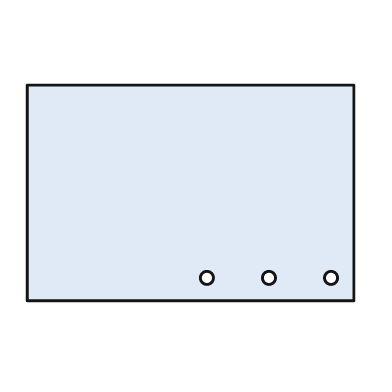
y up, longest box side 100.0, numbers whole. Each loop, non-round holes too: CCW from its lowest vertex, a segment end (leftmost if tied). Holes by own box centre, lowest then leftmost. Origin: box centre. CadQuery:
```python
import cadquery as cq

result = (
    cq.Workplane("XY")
    .moveTo(-50.0, -33.0)
    .lineTo(50.0, -33.0)
    .lineTo(50.0, 33.0)
    .lineTo(-50.0, 33.0)
    .close()
    .moveTo(5.0, -26.0)
    .circle(2.0)
    .moveTo(24.0, -26.0)
    .circle(2.0)
    .moveTo(43.0, -26.0)
    .circle(2.0)
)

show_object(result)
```